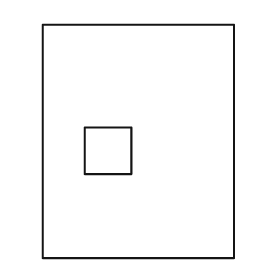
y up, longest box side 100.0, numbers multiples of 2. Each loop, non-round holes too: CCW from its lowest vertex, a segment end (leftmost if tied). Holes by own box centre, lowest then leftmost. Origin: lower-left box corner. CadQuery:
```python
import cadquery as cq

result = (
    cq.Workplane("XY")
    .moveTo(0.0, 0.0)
    .lineTo(82.0, 0.0)
    .lineTo(82.0, 100.0)
    .lineTo(0.0, 100.0)
    .close()
    .moveTo(18.0, 36.0)
    .lineTo(38.0, 36.0)
    .lineTo(38.0, 56.0)
    .lineTo(18.0, 56.0)
    .close()
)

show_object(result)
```